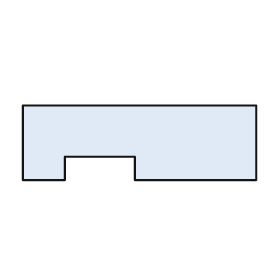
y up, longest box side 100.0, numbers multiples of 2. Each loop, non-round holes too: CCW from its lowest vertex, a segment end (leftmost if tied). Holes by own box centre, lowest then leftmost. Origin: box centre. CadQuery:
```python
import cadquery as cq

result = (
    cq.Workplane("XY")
    .moveTo(-50.0, -16.0)
    .lineTo(-32.0, -16.0)
    .lineTo(-32.0, -6.0)
    .lineTo(-2.0, -6.0)
    .lineTo(-2.0, -16.0)
    .lineTo(50.0, -16.0)
    .lineTo(50.0, 16.0)
    .lineTo(-50.0, 16.0)
    .close()
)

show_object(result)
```